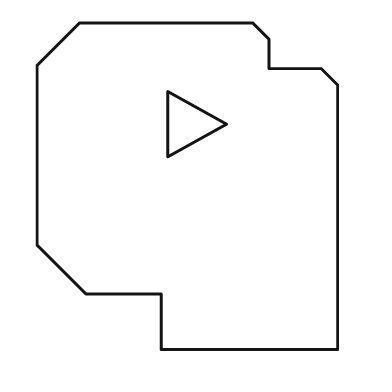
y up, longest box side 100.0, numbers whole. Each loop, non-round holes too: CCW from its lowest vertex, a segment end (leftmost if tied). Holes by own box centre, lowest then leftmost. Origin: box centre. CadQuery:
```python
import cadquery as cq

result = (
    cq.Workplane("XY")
    .moveTo(-8.0, -50.0)
    .lineTo(46.0, -50.0)
    .lineTo(46.0, 31.0)
    .lineTo(41.0, 36.0)
    .lineTo(25.0, 36.0)
    .lineTo(25.0, 45.0)
    .lineTo(20.0, 50.0)
    .lineTo(-33.0, 50.0)
    .lineTo(-46.0, 37.0)
    .lineTo(-46.0, -18.0)
    .lineTo(-31.0, -33.0)
    .lineTo(-8.0, -33.0)
    .close()
    .moveTo(-6.0, 9.0)
    .lineTo(12.0, 19.0)
    .lineTo(-6.0, 29.0)
    .close()
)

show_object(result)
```